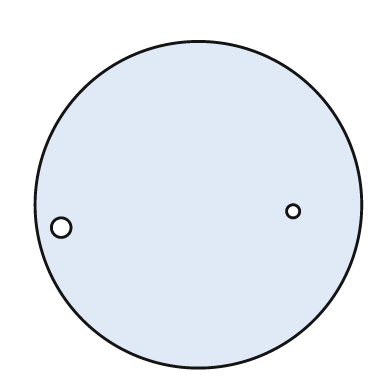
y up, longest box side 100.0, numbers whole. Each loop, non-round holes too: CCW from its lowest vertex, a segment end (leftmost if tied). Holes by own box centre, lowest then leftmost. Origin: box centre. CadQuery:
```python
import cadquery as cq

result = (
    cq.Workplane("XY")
    .moveTo(0.0, 0.0)
    .circle(50.0)
    .moveTo(-42.0, -7.0)
    .circle(3.0)
    .moveTo(29.0, -2.0)
    .circle(2.0)
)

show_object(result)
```